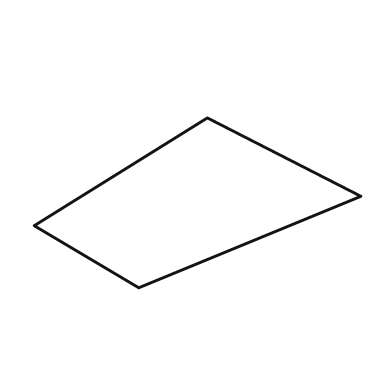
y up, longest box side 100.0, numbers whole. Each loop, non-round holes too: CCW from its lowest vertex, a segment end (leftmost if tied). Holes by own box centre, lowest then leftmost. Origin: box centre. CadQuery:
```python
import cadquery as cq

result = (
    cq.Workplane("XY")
    .moveTo(-18.0, -26.0)
    .lineTo(50.0, 2.0)
    .lineTo(3.0, 26.0)
    .lineTo(-50.0, -7.0)
    .close()
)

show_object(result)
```